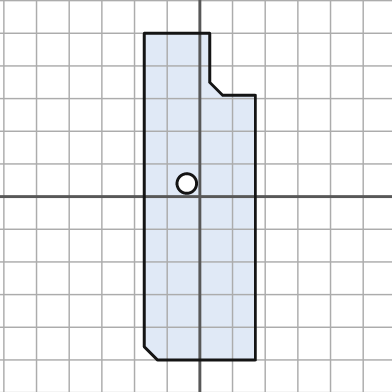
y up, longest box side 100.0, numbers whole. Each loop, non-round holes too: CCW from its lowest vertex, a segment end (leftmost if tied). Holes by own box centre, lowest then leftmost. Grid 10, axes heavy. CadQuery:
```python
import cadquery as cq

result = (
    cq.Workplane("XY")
    .moveTo(-13.0, -50.0)
    .lineTo(17.0, -50.0)
    .lineTo(17.0, 31.0)
    .lineTo(7.0, 31.0)
    .lineTo(3.0, 35.0)
    .lineTo(3.0, 50.0)
    .lineTo(-17.0, 50.0)
    .lineTo(-17.0, -46.0)
    .close()
    .moveTo(-4.0, 4.0)
    .circle(3.0)
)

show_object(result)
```